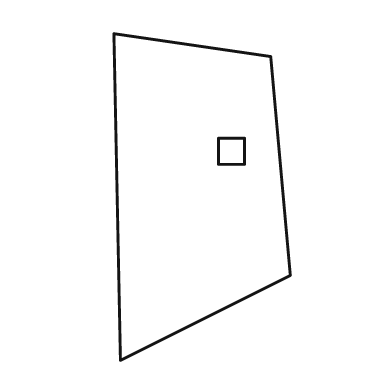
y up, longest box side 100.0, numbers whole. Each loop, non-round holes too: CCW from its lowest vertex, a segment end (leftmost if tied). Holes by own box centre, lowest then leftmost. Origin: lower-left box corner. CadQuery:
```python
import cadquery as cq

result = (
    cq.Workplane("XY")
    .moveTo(2.0, 0.0)
    .lineTo(54.0, 26.0)
    .lineTo(48.0, 93.0)
    .lineTo(0.0, 100.0)
    .close()
    .moveTo(32.0, 60.0)
    .lineTo(40.0, 60.0)
    .lineTo(40.0, 68.0)
    .lineTo(32.0, 68.0)
    .close()
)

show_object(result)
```